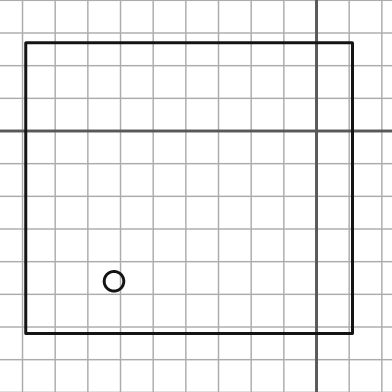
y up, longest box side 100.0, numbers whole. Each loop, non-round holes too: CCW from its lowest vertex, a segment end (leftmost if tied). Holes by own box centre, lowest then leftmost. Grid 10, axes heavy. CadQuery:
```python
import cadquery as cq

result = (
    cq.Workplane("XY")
    .moveTo(-89.0, -62.0)
    .lineTo(11.0, -62.0)
    .lineTo(11.0, 27.0)
    .lineTo(-89.0, 27.0)
    .close()
    .moveTo(-62.0, -46.0)
    .circle(3.0)
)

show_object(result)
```